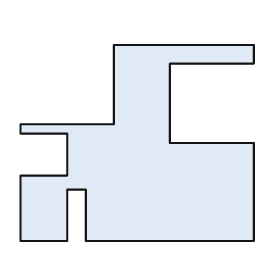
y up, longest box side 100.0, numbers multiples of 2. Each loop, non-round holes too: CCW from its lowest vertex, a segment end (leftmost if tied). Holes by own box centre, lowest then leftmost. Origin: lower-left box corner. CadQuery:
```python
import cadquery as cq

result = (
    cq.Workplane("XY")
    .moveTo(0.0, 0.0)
    .lineTo(20.0, 0.0)
    .lineTo(20.0, 22.0)
    .lineTo(28.0, 22.0)
    .lineTo(28.0, 0.0)
    .lineTo(100.0, 0.0)
    .lineTo(100.0, 42.0)
    .lineTo(64.0, 42.0)
    .lineTo(64.0, 76.0)
    .lineTo(100.0, 76.0)
    .lineTo(100.0, 84.0)
    .lineTo(40.0, 84.0)
    .lineTo(40.0, 50.0)
    .lineTo(0.0, 50.0)
    .lineTo(0.0, 46.0)
    .lineTo(20.0, 46.0)
    .lineTo(20.0, 28.0)
    .lineTo(0.0, 28.0)
    .close()
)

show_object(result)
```